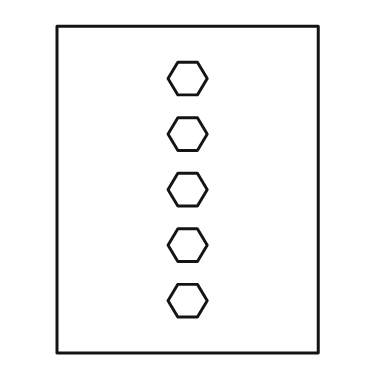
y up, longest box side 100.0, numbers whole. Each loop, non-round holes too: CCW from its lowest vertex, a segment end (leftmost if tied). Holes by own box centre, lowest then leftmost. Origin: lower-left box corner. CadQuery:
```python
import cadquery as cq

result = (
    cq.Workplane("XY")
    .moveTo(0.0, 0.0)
    .lineTo(80.0, 0.0)
    .lineTo(80.0, 100.0)
    .lineTo(0.0, 100.0)
    .close()
    .moveTo(37.0, 11.0)
    .lineTo(43.0, 11.0)
    .lineTo(46.0, 16.0)
    .lineTo(43.0, 21.0)
    .lineTo(37.0, 21.0)
    .lineTo(34.0, 16.0)
    .close()
    .moveTo(37.0, 28.0)
    .lineTo(43.0, 28.0)
    .lineTo(46.0, 33.0)
    .lineTo(43.0, 38.0)
    .lineTo(37.0, 38.0)
    .lineTo(34.0, 33.0)
    .close()
    .moveTo(37.0, 45.0)
    .lineTo(43.0, 45.0)
    .lineTo(46.0, 50.0)
    .lineTo(43.0, 55.0)
    .lineTo(37.0, 55.0)
    .lineTo(34.0, 50.0)
    .close()
    .moveTo(37.0, 62.0)
    .lineTo(43.0, 62.0)
    .lineTo(46.0, 67.0)
    .lineTo(43.0, 72.0)
    .lineTo(37.0, 72.0)
    .lineTo(34.0, 67.0)
    .close()
    .moveTo(37.0, 79.0)
    .lineTo(43.0, 79.0)
    .lineTo(46.0, 84.0)
    .lineTo(43.0, 89.0)
    .lineTo(37.0, 89.0)
    .lineTo(34.0, 84.0)
    .close()
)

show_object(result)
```